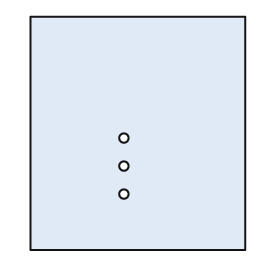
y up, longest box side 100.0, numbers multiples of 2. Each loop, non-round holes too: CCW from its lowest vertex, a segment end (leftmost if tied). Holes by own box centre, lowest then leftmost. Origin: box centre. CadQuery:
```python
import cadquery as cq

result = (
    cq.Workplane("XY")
    .moveTo(-46.0, -50.0)
    .lineTo(46.0, -50.0)
    .lineTo(46.0, 50.0)
    .lineTo(-46.0, 50.0)
    .close()
    .moveTo(-6.0, -26.0)
    .circle(2.0)
    .moveTo(-6.0, -14.0)
    .circle(2.0)
    .moveTo(-6.0, -2.0)
    .circle(2.0)
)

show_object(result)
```